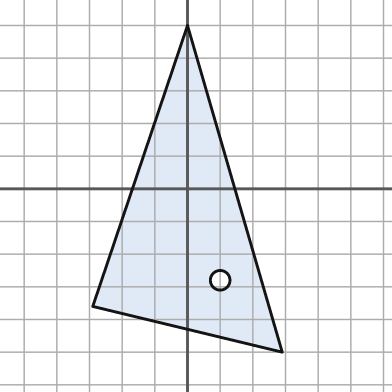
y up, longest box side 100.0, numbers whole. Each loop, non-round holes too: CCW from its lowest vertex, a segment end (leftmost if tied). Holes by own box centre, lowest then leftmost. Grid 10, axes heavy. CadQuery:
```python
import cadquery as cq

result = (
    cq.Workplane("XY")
    .moveTo(29.0, -50.0)
    .lineTo(0.0, 50.0)
    .lineTo(-29.0, -36.0)
    .close()
    .moveTo(10.0, -28.0)
    .circle(3.0)
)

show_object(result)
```